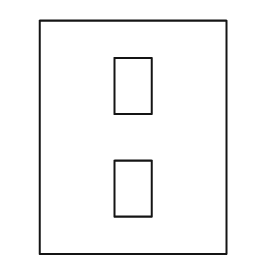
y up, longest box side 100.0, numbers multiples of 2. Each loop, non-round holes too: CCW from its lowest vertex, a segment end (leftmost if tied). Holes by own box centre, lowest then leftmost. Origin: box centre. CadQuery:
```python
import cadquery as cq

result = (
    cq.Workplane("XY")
    .moveTo(-40.0, -50.0)
    .lineTo(40.0, -50.0)
    .lineTo(40.0, 50.0)
    .lineTo(-40.0, 50.0)
    .close()
    .moveTo(-8.0, -34.0)
    .lineTo(8.0, -34.0)
    .lineTo(8.0, -10.0)
    .lineTo(-8.0, -10.0)
    .close()
    .moveTo(-8.0, 10.0)
    .lineTo(8.0, 10.0)
    .lineTo(8.0, 34.0)
    .lineTo(-8.0, 34.0)
    .close()
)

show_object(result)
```